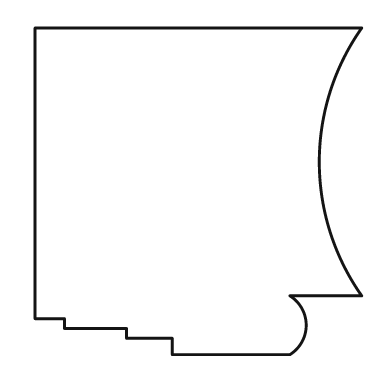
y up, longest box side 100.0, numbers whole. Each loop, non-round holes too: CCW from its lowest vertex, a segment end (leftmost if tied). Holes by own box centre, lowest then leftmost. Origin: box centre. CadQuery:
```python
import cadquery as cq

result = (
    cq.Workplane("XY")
    .moveTo(-8.0, -50.0)
    .lineTo(28.0, -50.0)
    .threePointArc((33.0, -41.0), (28.0, -32.0))
    .lineTo(50.0, -32.0)
    .threePointArc((37.0, 9.0), (50.0, 50.0))
    .lineTo(-50.0, 50.0)
    .lineTo(-50.0, -39.0)
    .lineTo(-41.0, -39.0)
    .lineTo(-41.0, -42.0)
    .lineTo(-22.0, -42.0)
    .lineTo(-22.0, -45.0)
    .lineTo(-8.0, -45.0)
    .close()
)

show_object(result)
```